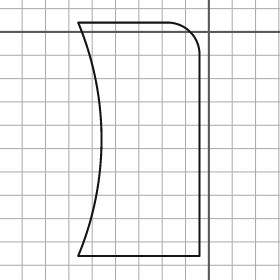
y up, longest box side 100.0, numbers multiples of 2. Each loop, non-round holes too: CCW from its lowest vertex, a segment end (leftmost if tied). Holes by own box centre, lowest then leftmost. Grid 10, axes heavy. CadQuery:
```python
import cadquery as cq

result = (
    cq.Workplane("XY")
    .moveTo(-56.0, -96.0)
    .lineTo(-4.0, -96.0)
    .lineTo(-4.0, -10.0)
    .threePointArc((-8.0, 0.0), (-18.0, 4.0))
    .lineTo(-56.0, 4.0)
    .threePointArc((-46.0, -46.0), (-56.0, -96.0))
    .close()
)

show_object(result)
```